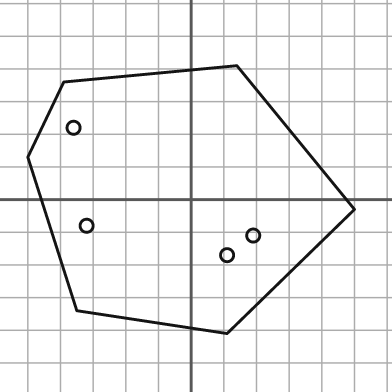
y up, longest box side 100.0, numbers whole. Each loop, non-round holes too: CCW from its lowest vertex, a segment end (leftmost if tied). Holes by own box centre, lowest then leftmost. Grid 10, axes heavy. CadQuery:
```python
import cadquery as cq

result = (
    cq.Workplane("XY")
    .moveTo(11.0, -41.0)
    .lineTo(50.0, -3.0)
    .lineTo(14.0, 41.0)
    .lineTo(-39.0, 36.0)
    .lineTo(-50.0, 13.0)
    .lineTo(-35.0, -34.0)
    .close()
    .moveTo(11.0, -17.0)
    .circle(2.0)
    .moveTo(19.0, -11.0)
    .circle(2.0)
    .moveTo(-32.0, -8.0)
    .circle(2.0)
    .moveTo(-36.0, 22.0)
    .circle(2.0)
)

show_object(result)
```